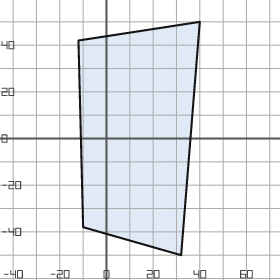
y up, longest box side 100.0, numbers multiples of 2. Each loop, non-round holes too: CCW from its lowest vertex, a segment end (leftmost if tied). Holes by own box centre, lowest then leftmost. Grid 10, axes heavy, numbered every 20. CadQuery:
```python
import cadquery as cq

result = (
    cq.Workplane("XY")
    .moveTo(32.0, -50.0)
    .lineTo(40.0, 50.0)
    .lineTo(-12.0, 42.0)
    .lineTo(-10.0, -38.0)
    .close()
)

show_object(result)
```